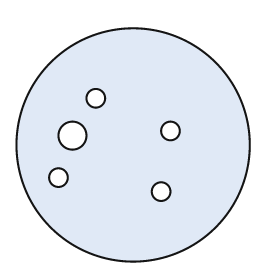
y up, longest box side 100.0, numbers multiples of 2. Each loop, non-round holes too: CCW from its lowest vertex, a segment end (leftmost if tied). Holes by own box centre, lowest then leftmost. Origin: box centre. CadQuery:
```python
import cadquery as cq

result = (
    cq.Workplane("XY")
    .moveTo(0.0, 0.0)
    .circle(50.0)
    .moveTo(12.0, -20.0)
    .circle(4.0)
    .moveTo(-32.0, -14.0)
    .circle(4.0)
    .moveTo(-26.0, 4.0)
    .circle(6.0)
    .moveTo(16.0, 6.0)
    .circle(4.0)
    .moveTo(-16.0, 20.0)
    .circle(4.0)
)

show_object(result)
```